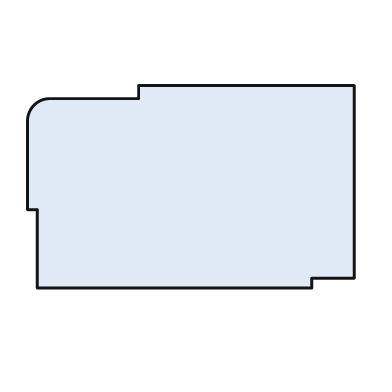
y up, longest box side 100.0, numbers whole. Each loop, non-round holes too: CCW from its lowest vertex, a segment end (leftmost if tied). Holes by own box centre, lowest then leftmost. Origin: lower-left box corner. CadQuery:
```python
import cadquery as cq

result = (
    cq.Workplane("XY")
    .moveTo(3.0, 0.0)
    .lineTo(87.0, 0.0)
    .lineTo(87.0, 3.0)
    .lineTo(100.0, 3.0)
    .lineTo(100.0, 62.0)
    .lineTo(34.0, 62.0)
    .lineTo(34.0, 58.0)
    .lineTo(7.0, 58.0)
    .threePointArc((2.0, 56.0), (0.0, 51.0))
    .lineTo(0.0, 24.0)
    .lineTo(3.0, 24.0)
    .close()
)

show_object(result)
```